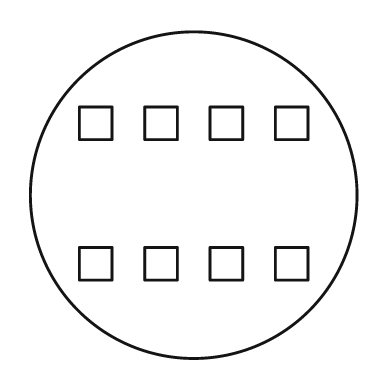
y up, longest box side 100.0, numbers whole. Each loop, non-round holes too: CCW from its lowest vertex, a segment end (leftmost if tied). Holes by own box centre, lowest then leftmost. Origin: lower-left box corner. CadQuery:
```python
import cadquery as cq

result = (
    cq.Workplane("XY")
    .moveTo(50.0, 50.0)
    .circle(50.0)
    .moveTo(15.0, 24.0)
    .lineTo(25.0, 24.0)
    .lineTo(25.0, 34.0)
    .lineTo(15.0, 34.0)
    .close()
    .moveTo(35.0, 24.0)
    .lineTo(45.0, 24.0)
    .lineTo(45.0, 34.0)
    .lineTo(35.0, 34.0)
    .close()
    .moveTo(55.0, 24.0)
    .lineTo(65.0, 24.0)
    .lineTo(65.0, 34.0)
    .lineTo(55.0, 34.0)
    .close()
    .moveTo(75.0, 24.0)
    .lineTo(85.0, 24.0)
    .lineTo(85.0, 34.0)
    .lineTo(75.0, 34.0)
    .close()
    .moveTo(15.0, 67.0)
    .lineTo(25.0, 67.0)
    .lineTo(25.0, 77.0)
    .lineTo(15.0, 77.0)
    .close()
    .moveTo(35.0, 67.0)
    .lineTo(45.0, 67.0)
    .lineTo(45.0, 77.0)
    .lineTo(35.0, 77.0)
    .close()
    .moveTo(55.0, 67.0)
    .lineTo(65.0, 67.0)
    .lineTo(65.0, 77.0)
    .lineTo(55.0, 77.0)
    .close()
    .moveTo(75.0, 67.0)
    .lineTo(85.0, 67.0)
    .lineTo(85.0, 77.0)
    .lineTo(75.0, 77.0)
    .close()
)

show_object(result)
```